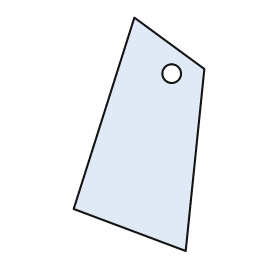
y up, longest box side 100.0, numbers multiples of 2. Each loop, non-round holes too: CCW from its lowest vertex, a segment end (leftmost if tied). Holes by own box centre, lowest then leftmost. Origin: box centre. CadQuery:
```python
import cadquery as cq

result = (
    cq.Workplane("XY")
    .moveTo(20.0, -50.0)
    .lineTo(28.0, 28.0)
    .lineTo(-2.0, 50.0)
    .lineTo(-28.0, -32.0)
    .close()
    .moveTo(14.0, 26.0)
    .circle(4.0)
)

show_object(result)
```